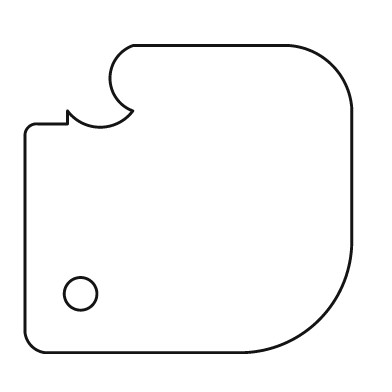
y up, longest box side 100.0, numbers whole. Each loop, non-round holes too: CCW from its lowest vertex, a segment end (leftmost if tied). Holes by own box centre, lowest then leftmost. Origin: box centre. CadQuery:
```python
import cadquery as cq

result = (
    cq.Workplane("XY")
    .moveTo(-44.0, -47.0)
    .lineTo(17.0, -47.0)
    .threePointArc((40.0, -37.0), (50.0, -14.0))
    .lineTo(50.0, 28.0)
    .threePointArc((44.0, 41.0), (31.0, 47.0))
    .lineTo(-17.0, 47.0)
    .threePointArc((-24.0, 37.0), (-17.0, 27.0))
    .threePointArc((-27.0, 22.0), (-37.0, 27.0))
    .lineTo(-37.0, 23.0)
    .lineTo(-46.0, 23.0)
    .threePointArc((-49.0, 22.0), (-50.0, 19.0))
    .lineTo(-50.0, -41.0)
    .threePointArc((-48.0, -45.0), (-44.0, -47.0))
    .close()
    .moveTo(-33.0, -29.0)
    .circle(5.0)
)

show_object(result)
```